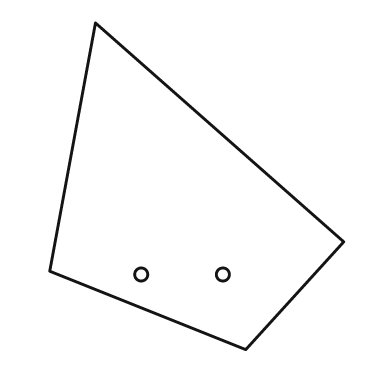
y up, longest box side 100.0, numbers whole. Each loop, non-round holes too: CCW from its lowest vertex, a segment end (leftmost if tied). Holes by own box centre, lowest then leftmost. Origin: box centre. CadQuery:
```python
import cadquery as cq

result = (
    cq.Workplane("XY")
    .moveTo(15.0, -50.0)
    .lineTo(45.0, -17.0)
    .lineTo(-31.0, 50.0)
    .lineTo(-45.0, -26.0)
    .close()
    .moveTo(-17.0, -27.0)
    .circle(2.0)
    .moveTo(8.0, -27.0)
    .circle(2.0)
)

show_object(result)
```